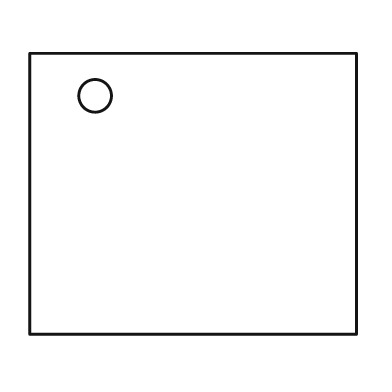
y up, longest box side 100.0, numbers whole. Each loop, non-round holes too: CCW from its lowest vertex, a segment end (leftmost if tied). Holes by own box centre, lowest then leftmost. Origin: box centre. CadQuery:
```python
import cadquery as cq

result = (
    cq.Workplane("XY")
    .moveTo(-50.0, -43.0)
    .lineTo(50.0, -43.0)
    .lineTo(50.0, 43.0)
    .lineTo(-50.0, 43.0)
    .close()
    .moveTo(-30.0, 30.0)
    .circle(5.0)
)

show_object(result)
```